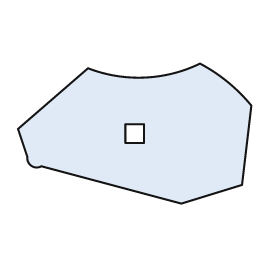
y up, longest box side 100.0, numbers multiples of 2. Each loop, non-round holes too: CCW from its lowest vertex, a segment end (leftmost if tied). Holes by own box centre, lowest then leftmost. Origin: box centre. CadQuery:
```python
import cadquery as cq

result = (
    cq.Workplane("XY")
    .moveTo(20.0, -30.0)
    .lineTo(46.0, -22.0)
    .lineTo(50.0, 12.0)
    .threePointArc((40.0, 22.0), (28.0, 30.0))
    .threePointArc((4.0, 24.0), (-20.0, 28.0))
    .lineTo(-50.0, 2.0)
    .lineTo(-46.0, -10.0)
    .threePointArc((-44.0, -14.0), (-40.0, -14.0))
    .close()
    .moveTo(-4.0, -4.0)
    .lineTo(4.0, -4.0)
    .lineTo(4.0, 4.0)
    .lineTo(-4.0, 4.0)
    .close()
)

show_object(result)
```